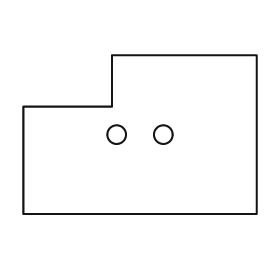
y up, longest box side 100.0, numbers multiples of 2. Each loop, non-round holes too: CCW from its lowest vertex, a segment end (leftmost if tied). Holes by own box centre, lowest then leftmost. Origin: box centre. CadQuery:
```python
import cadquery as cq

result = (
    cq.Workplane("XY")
    .moveTo(-50.0, -34.0)
    .lineTo(50.0, -34.0)
    .lineTo(50.0, 34.0)
    .lineTo(-12.0, 34.0)
    .lineTo(-12.0, 12.0)
    .lineTo(-50.0, 12.0)
    .close()
    .moveTo(-10.0, 0.0)
    .circle(4.0)
    .moveTo(10.0, 0.0)
    .circle(4.0)
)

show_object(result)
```